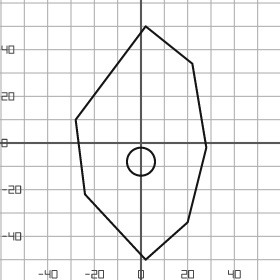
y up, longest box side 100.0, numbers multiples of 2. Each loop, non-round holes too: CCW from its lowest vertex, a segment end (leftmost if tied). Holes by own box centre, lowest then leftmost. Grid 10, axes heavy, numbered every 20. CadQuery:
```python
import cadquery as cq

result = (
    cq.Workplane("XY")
    .moveTo(2.0, -50.0)
    .lineTo(20.0, -34.0)
    .lineTo(28.0, -2.0)
    .lineTo(22.0, 34.0)
    .lineTo(2.0, 50.0)
    .lineTo(-28.0, 10.0)
    .lineTo(-24.0, -22.0)
    .close()
    .moveTo(0.0, -8.0)
    .circle(6.0)
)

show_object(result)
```